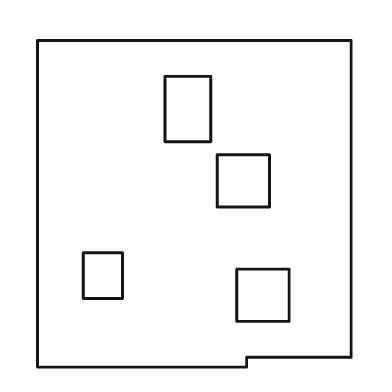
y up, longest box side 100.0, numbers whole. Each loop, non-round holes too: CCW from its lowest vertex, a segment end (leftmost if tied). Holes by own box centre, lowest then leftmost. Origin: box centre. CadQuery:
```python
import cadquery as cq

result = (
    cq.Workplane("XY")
    .moveTo(-48.0, -50.0)
    .lineTo(16.0, -50.0)
    .lineTo(16.0, -47.0)
    .lineTo(48.0, -47.0)
    .lineTo(48.0, 50.0)
    .lineTo(-48.0, 50.0)
    .close()
    .moveTo(13.0, -36.0)
    .lineTo(29.0, -36.0)
    .lineTo(29.0, -20.0)
    .lineTo(13.0, -20.0)
    .close()
    .moveTo(-34.0, -29.0)
    .lineTo(-22.0, -29.0)
    .lineTo(-22.0, -15.0)
    .lineTo(-34.0, -15.0)
    .close()
    .moveTo(7.0, -1.0)
    .lineTo(23.0, -1.0)
    .lineTo(23.0, 15.0)
    .lineTo(7.0, 15.0)
    .close()
    .moveTo(-9.0, 19.0)
    .lineTo(5.0, 19.0)
    .lineTo(5.0, 39.0)
    .lineTo(-9.0, 39.0)
    .close()
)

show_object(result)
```